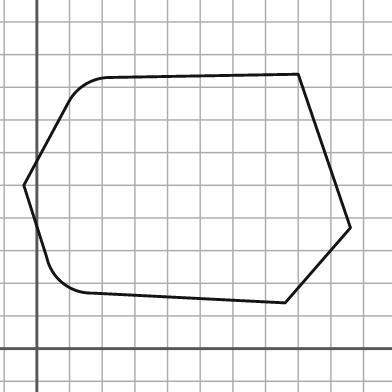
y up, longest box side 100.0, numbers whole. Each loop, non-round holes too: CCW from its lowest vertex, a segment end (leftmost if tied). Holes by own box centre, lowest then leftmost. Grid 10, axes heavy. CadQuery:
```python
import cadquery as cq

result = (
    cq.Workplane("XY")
    .moveTo(76.0, 14.0)
    .lineTo(96.0, 37.0)
    .lineTo(80.0, 84.0)
    .lineTo(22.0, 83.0)
    .threePointArc((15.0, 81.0), (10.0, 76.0))
    .lineTo(-4.0, 50.0)
    .lineTo(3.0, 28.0)
    .threePointArc((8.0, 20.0), (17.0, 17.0))
    .close()
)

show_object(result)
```